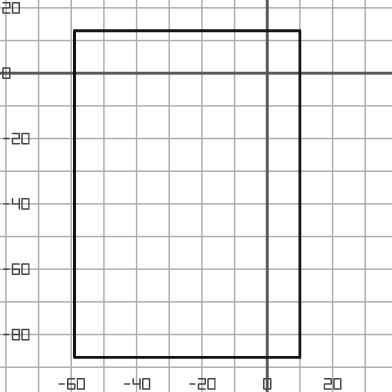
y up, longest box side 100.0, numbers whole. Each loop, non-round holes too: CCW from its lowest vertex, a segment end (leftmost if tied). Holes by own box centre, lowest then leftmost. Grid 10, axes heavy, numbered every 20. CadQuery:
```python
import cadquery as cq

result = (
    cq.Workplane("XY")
    .moveTo(-59.0, -87.0)
    .lineTo(10.0, -87.0)
    .lineTo(10.0, 13.0)
    .lineTo(-59.0, 13.0)
    .close()
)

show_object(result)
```